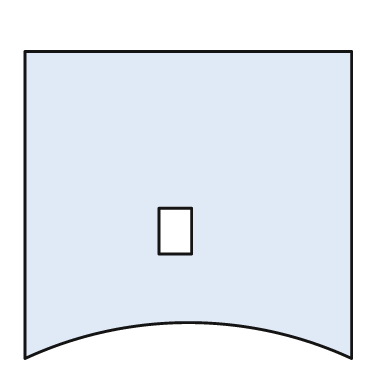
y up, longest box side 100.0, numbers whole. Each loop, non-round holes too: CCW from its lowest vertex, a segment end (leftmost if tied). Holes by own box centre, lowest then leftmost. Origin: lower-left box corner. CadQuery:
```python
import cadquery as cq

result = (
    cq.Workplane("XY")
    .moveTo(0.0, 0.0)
    .threePointArc((50.0, 11.0), (100.0, 0.0))
    .lineTo(100.0, 94.0)
    .lineTo(0.0, 94.0)
    .close()
    .moveTo(41.0, 32.0)
    .lineTo(51.0, 32.0)
    .lineTo(51.0, 46.0)
    .lineTo(41.0, 46.0)
    .close()
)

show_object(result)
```